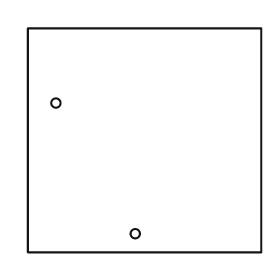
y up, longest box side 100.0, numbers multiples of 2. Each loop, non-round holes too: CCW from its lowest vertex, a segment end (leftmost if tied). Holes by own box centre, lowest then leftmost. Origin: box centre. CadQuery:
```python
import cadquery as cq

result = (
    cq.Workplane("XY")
    .moveTo(-50.0, -48.0)
    .lineTo(50.0, -48.0)
    .lineTo(50.0, 48.0)
    .lineTo(-50.0, 48.0)
    .close()
    .moveTo(-4.0, -40.0)
    .circle(2.0)
    .moveTo(-38.0, 16.0)
    .circle(2.0)
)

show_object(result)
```